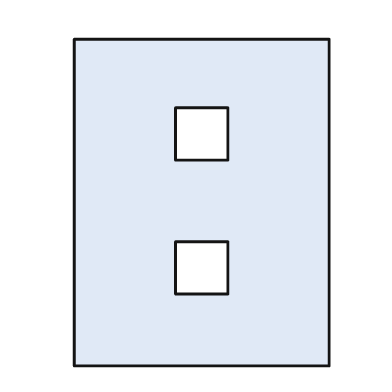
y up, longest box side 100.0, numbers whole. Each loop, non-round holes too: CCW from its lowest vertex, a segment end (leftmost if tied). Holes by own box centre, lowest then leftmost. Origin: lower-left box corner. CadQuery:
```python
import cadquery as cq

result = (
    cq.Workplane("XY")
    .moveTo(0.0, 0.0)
    .lineTo(78.0, 0.0)
    .lineTo(78.0, 100.0)
    .lineTo(0.0, 100.0)
    .close()
    .moveTo(31.0, 22.0)
    .lineTo(47.0, 22.0)
    .lineTo(47.0, 38.0)
    .lineTo(31.0, 38.0)
    .close()
    .moveTo(31.0, 63.0)
    .lineTo(47.0, 63.0)
    .lineTo(47.0, 79.0)
    .lineTo(31.0, 79.0)
    .close()
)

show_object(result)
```